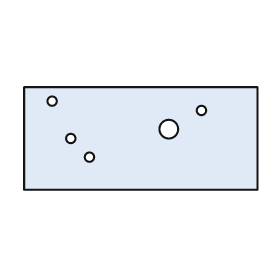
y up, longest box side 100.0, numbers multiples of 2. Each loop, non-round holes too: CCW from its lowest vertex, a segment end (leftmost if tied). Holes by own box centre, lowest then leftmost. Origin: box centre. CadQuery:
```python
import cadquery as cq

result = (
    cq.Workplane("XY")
    .moveTo(-50.0, -22.0)
    .lineTo(50.0, -22.0)
    .lineTo(50.0, 22.0)
    .lineTo(-50.0, 22.0)
    .close()
    .moveTo(-22.0, -8.0)
    .circle(2.0)
    .moveTo(-30.0, 0.0)
    .circle(2.0)
    .moveTo(12.0, 4.0)
    .circle(4.0)
    .moveTo(26.0, 12.0)
    .circle(2.0)
    .moveTo(-38.0, 16.0)
    .circle(2.0)
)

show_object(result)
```